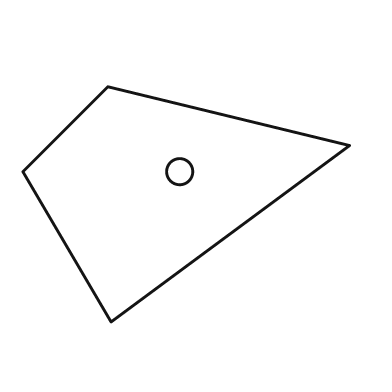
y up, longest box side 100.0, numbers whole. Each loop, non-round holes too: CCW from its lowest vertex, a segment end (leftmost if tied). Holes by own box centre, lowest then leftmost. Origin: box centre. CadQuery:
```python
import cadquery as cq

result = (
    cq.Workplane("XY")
    .moveTo(-23.0, -36.0)
    .lineTo(50.0, 18.0)
    .lineTo(-24.0, 36.0)
    .lineTo(-50.0, 10.0)
    .close()
    .moveTo(-2.0, 10.0)
    .circle(4.0)
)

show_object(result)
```